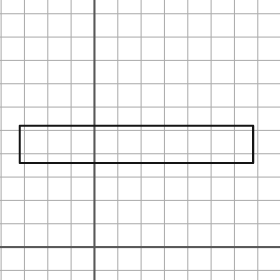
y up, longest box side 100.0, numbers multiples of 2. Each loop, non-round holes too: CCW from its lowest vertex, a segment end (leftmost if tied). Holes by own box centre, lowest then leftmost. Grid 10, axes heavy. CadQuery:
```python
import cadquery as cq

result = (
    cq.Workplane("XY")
    .moveTo(-32.0, 36.0)
    .lineTo(68.0, 36.0)
    .lineTo(68.0, 52.0)
    .lineTo(-32.0, 52.0)
    .close()
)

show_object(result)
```